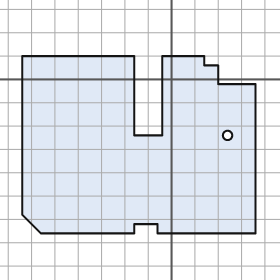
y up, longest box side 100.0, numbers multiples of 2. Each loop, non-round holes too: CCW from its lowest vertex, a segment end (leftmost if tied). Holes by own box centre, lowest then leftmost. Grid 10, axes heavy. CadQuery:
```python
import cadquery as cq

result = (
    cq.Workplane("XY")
    .moveTo(-56.0, -66.0)
    .lineTo(-16.0, -66.0)
    .lineTo(-16.0, -62.0)
    .lineTo(-6.0, -62.0)
    .lineTo(-6.0, -66.0)
    .lineTo(36.0, -66.0)
    .lineTo(36.0, -2.0)
    .lineTo(20.0, -2.0)
    .lineTo(20.0, 6.0)
    .lineTo(14.0, 6.0)
    .lineTo(14.0, 10.0)
    .lineTo(-4.0, 10.0)
    .lineTo(-4.0, -24.0)
    .lineTo(-16.0, -24.0)
    .lineTo(-16.0, 10.0)
    .lineTo(-64.0, 10.0)
    .lineTo(-64.0, -58.0)
    .close()
    .moveTo(24.0, -24.0)
    .circle(2.0)
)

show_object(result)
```